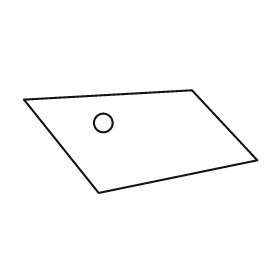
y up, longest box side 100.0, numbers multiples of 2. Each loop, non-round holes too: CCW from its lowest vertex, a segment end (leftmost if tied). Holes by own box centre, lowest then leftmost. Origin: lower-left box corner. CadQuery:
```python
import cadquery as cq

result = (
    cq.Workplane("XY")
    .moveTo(32.0, 0.0)
    .lineTo(100.0, 14.0)
    .lineTo(72.0, 44.0)
    .lineTo(0.0, 40.0)
    .close()
    .moveTo(34.0, 30.0)
    .circle(4.0)
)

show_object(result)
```